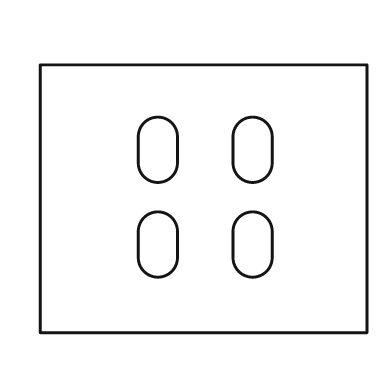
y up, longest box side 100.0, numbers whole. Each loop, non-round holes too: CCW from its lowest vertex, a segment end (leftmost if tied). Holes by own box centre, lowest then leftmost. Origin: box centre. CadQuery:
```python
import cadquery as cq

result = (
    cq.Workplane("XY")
    .moveTo(-50.0, -41.0)
    .lineTo(50.0, -41.0)
    .lineTo(50.0, 41.0)
    .lineTo(-50.0, 41.0)
    .close()
    .moveTo(-20.0, -18.0)
    .threePointArc((-14.0, -24.0), (-8.0, -18.0))
    .lineTo(-8.0, -10.0)
    .threePointArc((-14.0, -4.0), (-20.0, -10.0))
    .close()
    .moveTo(9.0, -18.0)
    .threePointArc((15.0, -24.0), (21.0, -18.0))
    .lineTo(21.0, -10.0)
    .threePointArc((15.0, -4.0), (9.0, -10.0))
    .close()
    .moveTo(-20.0, 11.0)
    .threePointArc((-14.0, 5.0), (-8.0, 11.0))
    .lineTo(-8.0, 19.0)
    .threePointArc((-14.0, 25.0), (-20.0, 19.0))
    .close()
    .moveTo(9.0, 11.0)
    .threePointArc((15.0, 5.0), (21.0, 11.0))
    .lineTo(21.0, 19.0)
    .threePointArc((15.0, 25.0), (9.0, 19.0))
    .close()
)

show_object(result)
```